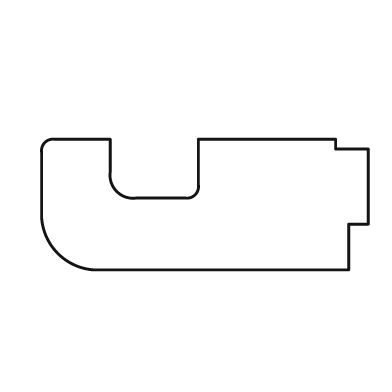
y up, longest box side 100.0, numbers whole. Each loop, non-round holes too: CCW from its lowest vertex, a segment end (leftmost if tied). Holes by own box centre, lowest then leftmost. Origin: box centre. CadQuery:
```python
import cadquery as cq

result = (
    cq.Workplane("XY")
    .moveTo(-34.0, -20.0)
    .lineTo(44.0, -20.0)
    .lineTo(44.0, -6.0)
    .lineTo(50.0, -6.0)
    .lineTo(50.0, 17.0)
    .lineTo(40.0, 17.0)
    .lineTo(40.0, 20.0)
    .lineTo(-2.0, 20.0)
    .lineTo(-2.0, 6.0)
    .threePointArc((-3.0, 3.0), (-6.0, 2.0))
    .lineTo(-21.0, 2.0)
    .threePointArc((-27.0, 4.0), (-29.0, 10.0))
    .lineTo(-29.0, 20.0)
    .lineTo(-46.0, 20.0)
    .threePointArc((-49.0, 19.0), (-50.0, 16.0))
    .lineTo(-50.0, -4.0)
    .threePointArc((-45.0, -15.0), (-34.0, -20.0))
    .close()
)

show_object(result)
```